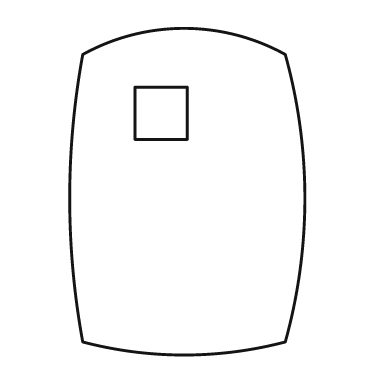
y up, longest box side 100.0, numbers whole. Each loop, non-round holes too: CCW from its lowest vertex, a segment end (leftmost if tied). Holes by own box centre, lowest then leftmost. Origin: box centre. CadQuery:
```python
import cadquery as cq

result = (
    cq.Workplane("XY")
    .moveTo(-32.0, -46.0)
    .threePointArc((-1.0, -50.0), (30.0, -46.0))
    .threePointArc((36.0, -2.0), (30.0, 42.0))
    .threePointArc((-1.0, 50.0), (-32.0, 42.0))
    .threePointArc((-36.0, -2.0), (-32.0, -46.0))
    .close()
    .moveTo(-16.0, 16.0)
    .lineTo(0.0, 16.0)
    .lineTo(0.0, 32.0)
    .lineTo(-16.0, 32.0)
    .close()
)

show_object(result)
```